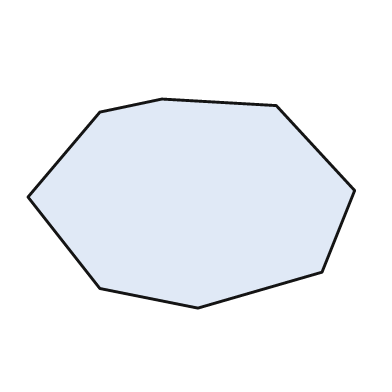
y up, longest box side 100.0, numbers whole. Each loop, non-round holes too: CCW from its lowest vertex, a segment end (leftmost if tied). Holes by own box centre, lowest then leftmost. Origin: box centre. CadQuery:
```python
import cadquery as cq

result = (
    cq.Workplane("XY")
    .moveTo(2.0, -32.0)
    .lineTo(40.0, -21.0)
    .lineTo(50.0, 4.0)
    .lineTo(26.0, 30.0)
    .lineTo(-9.0, 32.0)
    .lineTo(-28.0, 28.0)
    .lineTo(-50.0, 2.0)
    .lineTo(-28.0, -26.0)
    .close()
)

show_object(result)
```